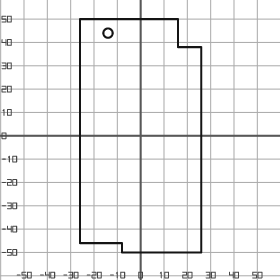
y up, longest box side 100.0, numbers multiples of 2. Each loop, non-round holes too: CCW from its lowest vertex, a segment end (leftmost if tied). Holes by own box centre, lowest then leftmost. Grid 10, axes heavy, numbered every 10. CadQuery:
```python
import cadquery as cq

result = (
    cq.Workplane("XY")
    .moveTo(-8.0, -50.0)
    .lineTo(26.0, -50.0)
    .lineTo(26.0, 38.0)
    .lineTo(16.0, 38.0)
    .lineTo(16.0, 50.0)
    .lineTo(-26.0, 50.0)
    .lineTo(-26.0, -46.0)
    .lineTo(-8.0, -46.0)
    .close()
    .moveTo(-14.0, 44.0)
    .circle(2.0)
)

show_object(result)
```